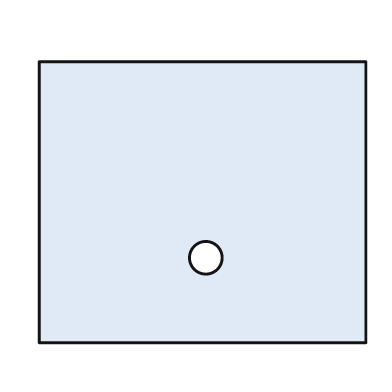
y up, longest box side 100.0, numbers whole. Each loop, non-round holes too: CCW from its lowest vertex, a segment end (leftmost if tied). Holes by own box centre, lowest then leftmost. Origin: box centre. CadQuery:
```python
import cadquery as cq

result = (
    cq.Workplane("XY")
    .moveTo(-50.0, -43.0)
    .lineTo(50.0, -43.0)
    .lineTo(50.0, 43.0)
    .lineTo(-50.0, 43.0)
    .close()
    .moveTo(1.0, -17.0)
    .circle(5.0)
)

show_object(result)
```